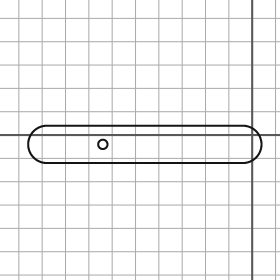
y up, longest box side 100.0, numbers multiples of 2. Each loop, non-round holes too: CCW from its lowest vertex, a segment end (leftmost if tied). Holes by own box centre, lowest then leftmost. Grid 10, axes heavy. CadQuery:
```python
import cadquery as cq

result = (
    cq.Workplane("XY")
    .moveTo(-88.0, -12.0)
    .lineTo(-4.0, -12.0)
    .threePointArc((4.0, -4.0), (-4.0, 4.0))
    .lineTo(-88.0, 4.0)
    .threePointArc((-96.0, -4.0), (-88.0, -12.0))
    .close()
    .moveTo(-64.0, -4.0)
    .circle(2.0)
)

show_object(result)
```